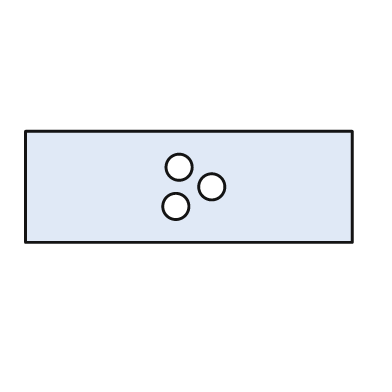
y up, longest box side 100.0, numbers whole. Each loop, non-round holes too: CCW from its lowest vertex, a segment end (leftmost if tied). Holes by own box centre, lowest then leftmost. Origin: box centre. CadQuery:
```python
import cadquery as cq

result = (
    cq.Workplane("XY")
    .moveTo(-50.0, -17.0)
    .lineTo(50.0, -17.0)
    .lineTo(50.0, 17.0)
    .lineTo(-50.0, 17.0)
    .close()
    .moveTo(-4.0, -6.0)
    .circle(4.0)
    .moveTo(7.0, 0.0)
    .circle(4.0)
    .moveTo(-3.0, 6.0)
    .circle(4.0)
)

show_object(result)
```